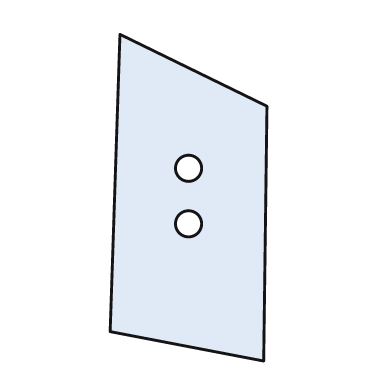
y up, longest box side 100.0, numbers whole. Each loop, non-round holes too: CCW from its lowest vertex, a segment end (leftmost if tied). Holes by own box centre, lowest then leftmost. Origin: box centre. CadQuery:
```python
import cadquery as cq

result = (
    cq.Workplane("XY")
    .moveTo(23.0, -50.0)
    .lineTo(24.0, 28.0)
    .lineTo(-21.0, 50.0)
    .lineTo(-24.0, -41.0)
    .close()
    .moveTo(0.0, -8.0)
    .circle(4.0)
    .moveTo(0.0, 9.0)
    .circle(4.0)
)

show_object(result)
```